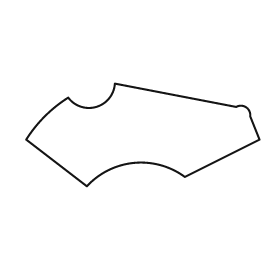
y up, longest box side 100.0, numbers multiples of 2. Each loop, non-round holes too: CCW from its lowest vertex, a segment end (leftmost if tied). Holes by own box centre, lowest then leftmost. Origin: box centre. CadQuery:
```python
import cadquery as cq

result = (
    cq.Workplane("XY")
    .moveTo(-24.0, -22.0)
    .threePointArc((-4.0, -12.0), (18.0, -18.0))
    .lineTo(50.0, -2.0)
    .lineTo(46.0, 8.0)
    .threePointArc((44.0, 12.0), (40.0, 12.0))
    .lineTo(-12.0, 22.0)
    .threePointArc((-20.0, 12.0), (-32.0, 16.0))
    .threePointArc((-42.0, 8.0), (-50.0, -2.0))
    .close()
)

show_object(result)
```